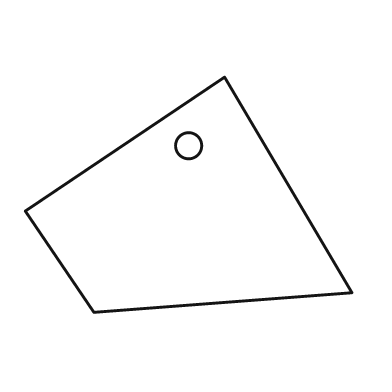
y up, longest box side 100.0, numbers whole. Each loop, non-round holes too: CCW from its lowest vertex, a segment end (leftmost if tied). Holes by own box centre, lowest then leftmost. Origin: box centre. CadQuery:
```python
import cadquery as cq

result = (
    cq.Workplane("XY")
    .moveTo(-29.0, -36.0)
    .lineTo(50.0, -30.0)
    .lineTo(11.0, 36.0)
    .lineTo(-50.0, -5.0)
    .close()
    .moveTo(0.0, 15.0)
    .circle(4.0)
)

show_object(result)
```